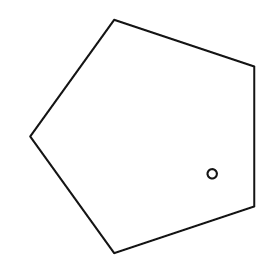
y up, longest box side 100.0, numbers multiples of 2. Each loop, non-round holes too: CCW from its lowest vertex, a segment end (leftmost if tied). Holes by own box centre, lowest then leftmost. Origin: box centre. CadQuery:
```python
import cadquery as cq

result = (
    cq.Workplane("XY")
    .moveTo(-12.0, -50.0)
    .lineTo(48.0, -30.0)
    .lineTo(48.0, 30.0)
    .lineTo(-12.0, 50.0)
    .lineTo(-48.0, 0.0)
    .close()
    .moveTo(30.0, -16.0)
    .circle(2.0)
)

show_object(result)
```